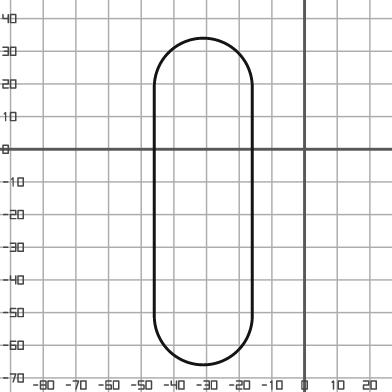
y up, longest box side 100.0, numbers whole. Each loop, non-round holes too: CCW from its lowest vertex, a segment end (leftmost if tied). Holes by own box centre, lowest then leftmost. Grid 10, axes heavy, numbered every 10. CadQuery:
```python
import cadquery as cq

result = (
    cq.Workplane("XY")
    .moveTo(-46.0, -51.0)
    .threePointArc((-31.0, -66.0), (-16.0, -51.0))
    .lineTo(-16.0, 19.0)
    .threePointArc((-31.0, 34.0), (-46.0, 19.0))
    .close()
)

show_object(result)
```